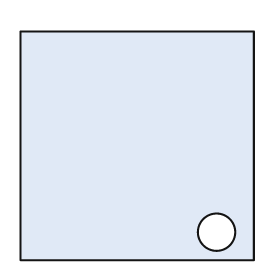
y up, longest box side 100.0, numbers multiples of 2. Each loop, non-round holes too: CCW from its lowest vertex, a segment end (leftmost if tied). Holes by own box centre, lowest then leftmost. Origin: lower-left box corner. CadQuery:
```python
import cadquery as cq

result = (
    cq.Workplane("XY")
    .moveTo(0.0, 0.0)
    .lineTo(100.0, 0.0)
    .lineTo(100.0, 98.0)
    .lineTo(0.0, 98.0)
    .close()
    .moveTo(84.0, 12.0)
    .circle(8.0)
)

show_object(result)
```